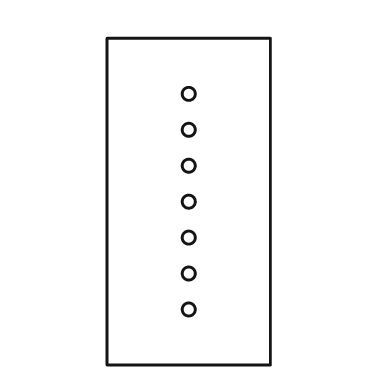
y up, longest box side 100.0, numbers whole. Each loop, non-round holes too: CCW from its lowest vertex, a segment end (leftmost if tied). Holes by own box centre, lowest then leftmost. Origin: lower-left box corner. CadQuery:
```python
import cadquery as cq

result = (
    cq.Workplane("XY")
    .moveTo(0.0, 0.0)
    .lineTo(50.0, 0.0)
    .lineTo(50.0, 100.0)
    .lineTo(0.0, 100.0)
    .close()
    .moveTo(25.0, 17.0)
    .circle(2.0)
    .moveTo(25.0, 28.0)
    .circle(2.0)
    .moveTo(25.0, 39.0)
    .circle(2.0)
    .moveTo(25.0, 50.0)
    .circle(2.0)
    .moveTo(25.0, 61.0)
    .circle(2.0)
    .moveTo(25.0, 72.0)
    .circle(2.0)
    .moveTo(25.0, 83.0)
    .circle(2.0)
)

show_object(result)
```